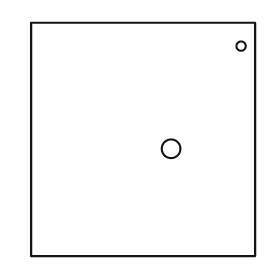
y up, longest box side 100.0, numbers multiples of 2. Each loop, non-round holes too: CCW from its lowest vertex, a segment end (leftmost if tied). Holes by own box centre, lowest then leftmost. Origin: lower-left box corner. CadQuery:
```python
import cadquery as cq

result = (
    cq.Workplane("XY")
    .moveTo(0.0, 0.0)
    .lineTo(96.0, 0.0)
    .lineTo(96.0, 100.0)
    .lineTo(0.0, 100.0)
    .close()
    .moveTo(60.0, 46.0)
    .circle(4.0)
    .moveTo(90.0, 90.0)
    .circle(2.0)
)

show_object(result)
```